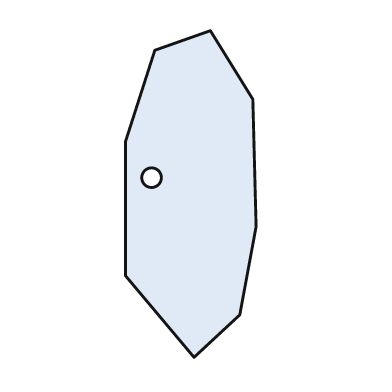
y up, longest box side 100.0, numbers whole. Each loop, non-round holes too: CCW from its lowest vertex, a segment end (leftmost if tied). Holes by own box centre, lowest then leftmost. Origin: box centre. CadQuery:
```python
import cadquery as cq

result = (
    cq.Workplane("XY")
    .moveTo(1.0, -50.0)
    .lineTo(15.0, -37.0)
    .lineTo(20.0, -10.0)
    .lineTo(19.0, 29.0)
    .lineTo(6.0, 50.0)
    .lineTo(-11.0, 44.0)
    .lineTo(-20.0, 16.0)
    .lineTo(-20.0, -25.0)
    .close()
    .moveTo(-12.0, 5.0)
    .circle(3.0)
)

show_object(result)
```